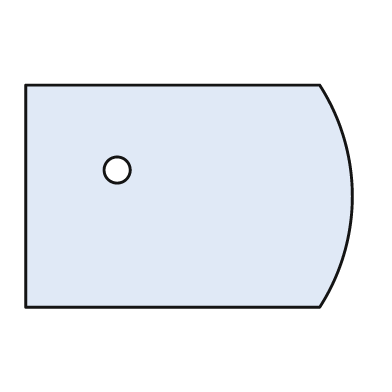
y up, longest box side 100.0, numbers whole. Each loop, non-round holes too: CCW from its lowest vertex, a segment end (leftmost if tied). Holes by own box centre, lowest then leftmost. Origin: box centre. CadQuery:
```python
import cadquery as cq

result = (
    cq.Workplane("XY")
    .moveTo(-50.0, -34.0)
    .lineTo(40.0, -34.0)
    .threePointArc((50.0, 0.0), (40.0, 34.0))
    .lineTo(-50.0, 34.0)
    .close()
    .moveTo(-22.0, 8.0)
    .circle(4.0)
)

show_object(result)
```